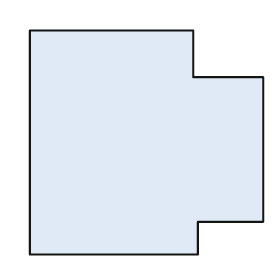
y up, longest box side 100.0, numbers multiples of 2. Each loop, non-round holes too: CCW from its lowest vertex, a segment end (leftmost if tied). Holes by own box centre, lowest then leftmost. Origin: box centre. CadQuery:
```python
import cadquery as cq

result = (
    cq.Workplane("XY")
    .moveTo(-50.0, -48.0)
    .lineTo(22.0, -48.0)
    .lineTo(22.0, -34.0)
    .lineTo(50.0, -34.0)
    .lineTo(50.0, 28.0)
    .lineTo(20.0, 28.0)
    .lineTo(20.0, 48.0)
    .lineTo(-50.0, 48.0)
    .close()
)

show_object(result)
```